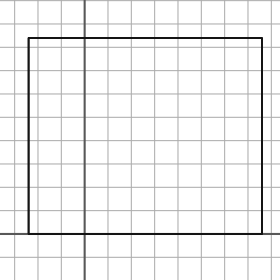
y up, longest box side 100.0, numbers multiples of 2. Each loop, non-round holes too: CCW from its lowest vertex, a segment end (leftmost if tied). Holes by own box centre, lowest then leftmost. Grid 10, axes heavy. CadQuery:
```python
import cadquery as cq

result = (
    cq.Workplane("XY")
    .moveTo(-24.0, 0.0)
    .lineTo(76.0, 0.0)
    .lineTo(76.0, 84.0)
    .lineTo(-24.0, 84.0)
    .close()
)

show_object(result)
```